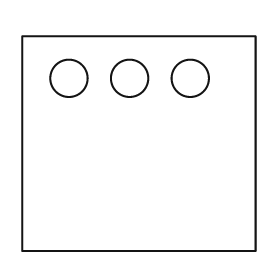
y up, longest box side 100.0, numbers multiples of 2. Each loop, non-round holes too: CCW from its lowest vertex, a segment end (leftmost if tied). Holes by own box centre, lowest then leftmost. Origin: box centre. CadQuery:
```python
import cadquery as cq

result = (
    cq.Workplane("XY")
    .moveTo(-50.0, -46.0)
    .lineTo(50.0, -46.0)
    .lineTo(50.0, 46.0)
    .lineTo(-50.0, 46.0)
    .close()
    .moveTo(-30.0, 28.0)
    .circle(8.0)
    .moveTo(-4.0, 28.0)
    .circle(8.0)
    .moveTo(22.0, 28.0)
    .circle(8.0)
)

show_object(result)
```